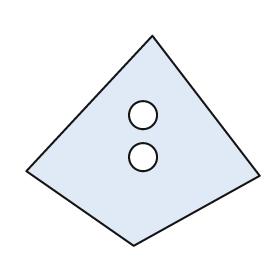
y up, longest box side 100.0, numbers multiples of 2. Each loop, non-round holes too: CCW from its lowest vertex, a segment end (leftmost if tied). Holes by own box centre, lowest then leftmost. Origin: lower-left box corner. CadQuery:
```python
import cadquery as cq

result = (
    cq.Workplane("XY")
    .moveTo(46.0, 0.0)
    .lineTo(100.0, 30.0)
    .lineTo(54.0, 90.0)
    .lineTo(0.0, 32.0)
    .close()
    .moveTo(50.0, 38.0)
    .circle(6.0)
    .moveTo(50.0, 56.0)
    .circle(6.0)
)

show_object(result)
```